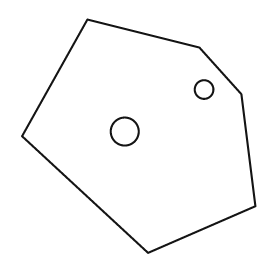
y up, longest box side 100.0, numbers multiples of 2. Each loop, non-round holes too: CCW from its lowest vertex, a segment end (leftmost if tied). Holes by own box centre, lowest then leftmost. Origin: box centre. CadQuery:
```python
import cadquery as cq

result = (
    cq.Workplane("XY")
    .moveTo(4.0, -50.0)
    .lineTo(50.0, -30.0)
    .lineTo(44.0, 18.0)
    .lineTo(26.0, 38.0)
    .lineTo(-22.0, 50.0)
    .lineTo(-50.0, 0.0)
    .close()
    .moveTo(-6.0, 2.0)
    .circle(6.0)
    .moveTo(28.0, 20.0)
    .circle(4.0)
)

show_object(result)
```